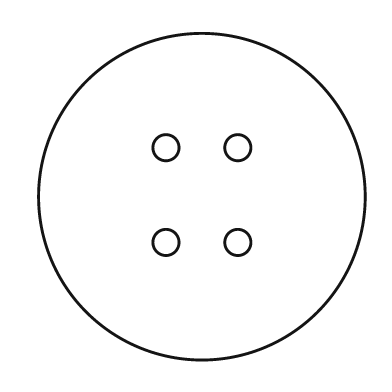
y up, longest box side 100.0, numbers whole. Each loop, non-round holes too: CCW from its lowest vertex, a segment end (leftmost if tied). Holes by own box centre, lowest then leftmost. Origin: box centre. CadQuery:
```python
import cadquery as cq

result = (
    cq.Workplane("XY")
    .moveTo(0.0, 0.0)
    .circle(50.0)
    .moveTo(-11.0, -14.0)
    .circle(4.0)
    .moveTo(11.0, -14.0)
    .circle(4.0)
    .moveTo(-11.0, 15.0)
    .circle(4.0)
    .moveTo(11.0, 15.0)
    .circle(4.0)
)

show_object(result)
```